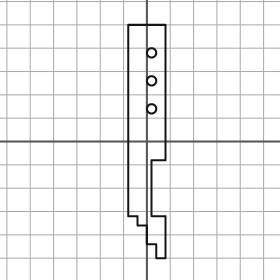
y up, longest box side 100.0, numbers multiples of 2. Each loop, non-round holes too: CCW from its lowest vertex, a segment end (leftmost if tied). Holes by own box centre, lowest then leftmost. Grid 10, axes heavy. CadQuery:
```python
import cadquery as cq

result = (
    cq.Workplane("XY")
    .moveTo(4.0, -50.0)
    .lineTo(8.0, -50.0)
    .lineTo(8.0, -32.0)
    .lineTo(2.0, -32.0)
    .lineTo(2.0, -8.0)
    .lineTo(8.0, -8.0)
    .lineTo(8.0, 50.0)
    .lineTo(-8.0, 50.0)
    .lineTo(-8.0, -32.0)
    .lineTo(-4.0, -32.0)
    .lineTo(-4.0, -36.0)
    .lineTo(0.0, -36.0)
    .lineTo(0.0, -44.0)
    .lineTo(4.0, -44.0)
    .close()
    .moveTo(2.0, 14.0)
    .circle(2.0)
    .moveTo(2.0, 26.0)
    .circle(2.0)
    .moveTo(2.0, 38.0)
    .circle(2.0)
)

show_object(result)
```